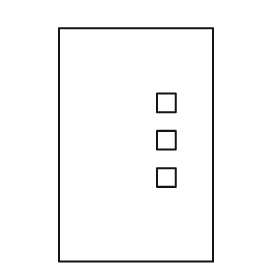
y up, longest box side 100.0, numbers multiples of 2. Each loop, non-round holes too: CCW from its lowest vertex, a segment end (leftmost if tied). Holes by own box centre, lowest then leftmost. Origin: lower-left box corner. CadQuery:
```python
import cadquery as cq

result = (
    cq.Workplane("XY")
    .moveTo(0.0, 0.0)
    .lineTo(66.0, 0.0)
    .lineTo(66.0, 100.0)
    .lineTo(0.0, 100.0)
    .close()
    .moveTo(42.0, 32.0)
    .lineTo(50.0, 32.0)
    .lineTo(50.0, 40.0)
    .lineTo(42.0, 40.0)
    .close()
    .moveTo(42.0, 48.0)
    .lineTo(50.0, 48.0)
    .lineTo(50.0, 56.0)
    .lineTo(42.0, 56.0)
    .close()
    .moveTo(42.0, 64.0)
    .lineTo(50.0, 64.0)
    .lineTo(50.0, 72.0)
    .lineTo(42.0, 72.0)
    .close()
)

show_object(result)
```